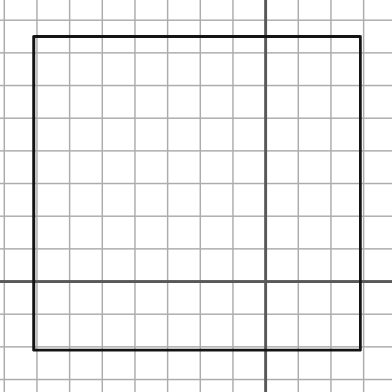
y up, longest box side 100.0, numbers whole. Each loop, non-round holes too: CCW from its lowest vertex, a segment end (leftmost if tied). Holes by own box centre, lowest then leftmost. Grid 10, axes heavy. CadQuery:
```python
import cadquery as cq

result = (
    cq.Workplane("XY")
    .moveTo(-71.0, -21.0)
    .lineTo(29.0, -21.0)
    .lineTo(29.0, 75.0)
    .lineTo(-71.0, 75.0)
    .close()
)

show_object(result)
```